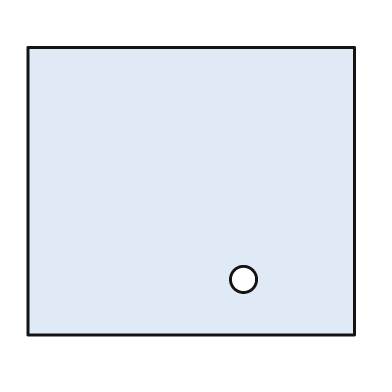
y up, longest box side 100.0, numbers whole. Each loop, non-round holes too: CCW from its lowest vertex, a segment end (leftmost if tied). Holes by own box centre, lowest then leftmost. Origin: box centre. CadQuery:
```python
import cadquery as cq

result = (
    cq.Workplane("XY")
    .moveTo(-50.0, -44.0)
    .lineTo(50.0, -44.0)
    .lineTo(50.0, 44.0)
    .lineTo(-50.0, 44.0)
    .close()
    .moveTo(16.0, -27.0)
    .circle(4.0)
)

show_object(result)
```